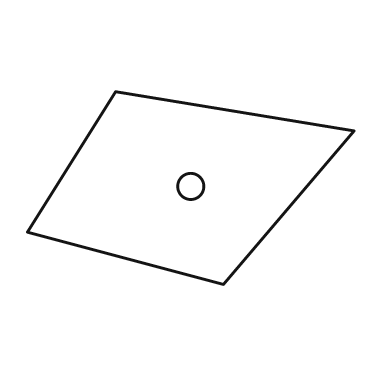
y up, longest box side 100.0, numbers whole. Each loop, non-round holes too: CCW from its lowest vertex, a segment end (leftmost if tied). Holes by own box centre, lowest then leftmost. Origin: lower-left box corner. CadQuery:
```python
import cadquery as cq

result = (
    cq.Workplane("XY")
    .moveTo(60.0, 0.0)
    .lineTo(100.0, 47.0)
    .lineTo(27.0, 59.0)
    .lineTo(0.0, 16.0)
    .close()
    .moveTo(50.0, 30.0)
    .circle(4.0)
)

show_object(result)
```